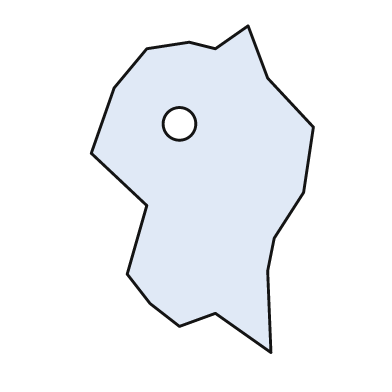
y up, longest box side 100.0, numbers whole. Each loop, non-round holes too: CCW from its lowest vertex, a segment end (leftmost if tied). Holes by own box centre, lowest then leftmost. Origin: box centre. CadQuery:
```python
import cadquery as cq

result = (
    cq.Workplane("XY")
    .moveTo(21.0, -50.0)
    .lineTo(20.0, -25.0)
    .lineTo(22.0, -15.0)
    .lineTo(31.0, -1.0)
    .lineTo(34.0, 19.0)
    .lineTo(20.0, 34.0)
    .lineTo(14.0, 50.0)
    .lineTo(4.0, 43.0)
    .lineTo(-4.0, 45.0)
    .lineTo(-17.0, 43.0)
    .lineTo(-27.0, 31.0)
    .lineTo(-34.0, 11.0)
    .lineTo(-17.0, -5.0)
    .lineTo(-23.0, -26.0)
    .lineTo(-16.0, -35.0)
    .lineTo(-7.0, -42.0)
    .lineTo(4.0, -38.0)
    .close()
    .moveTo(-7.0, 20.0)
    .circle(5.0)
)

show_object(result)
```